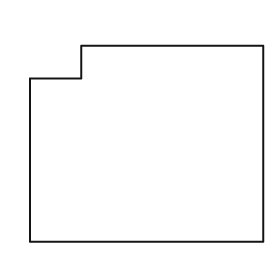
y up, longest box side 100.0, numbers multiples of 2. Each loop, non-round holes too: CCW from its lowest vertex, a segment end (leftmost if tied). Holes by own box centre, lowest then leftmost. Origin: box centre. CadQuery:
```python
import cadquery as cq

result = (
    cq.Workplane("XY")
    .moveTo(-50.0, -42.0)
    .lineTo(50.0, -42.0)
    .lineTo(50.0, 42.0)
    .lineTo(-28.0, 42.0)
    .lineTo(-28.0, 28.0)
    .lineTo(-50.0, 28.0)
    .close()
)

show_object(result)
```